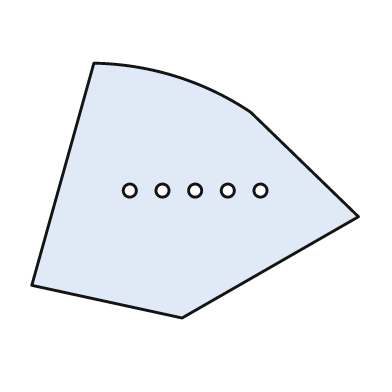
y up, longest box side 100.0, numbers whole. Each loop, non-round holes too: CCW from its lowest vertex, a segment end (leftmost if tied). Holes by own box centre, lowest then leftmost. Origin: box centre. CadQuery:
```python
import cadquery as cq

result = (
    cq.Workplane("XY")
    .moveTo(-4.0, -39.0)
    .lineTo(50.0, -8.0)
    .lineTo(17.0, 24.0)
    .threePointArc((-6.0, 35.0), (-31.0, 39.0))
    .lineTo(-50.0, -29.0)
    .close()
    .moveTo(-20.0, 0.0)
    .circle(2.0)
    .moveTo(-10.0, 0.0)
    .circle(2.0)
    .moveTo(0.0, 0.0)
    .circle(2.0)
    .moveTo(10.0, 0.0)
    .circle(2.0)
    .moveTo(20.0, 0.0)
    .circle(2.0)
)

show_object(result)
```